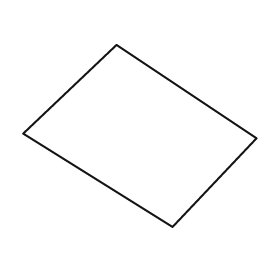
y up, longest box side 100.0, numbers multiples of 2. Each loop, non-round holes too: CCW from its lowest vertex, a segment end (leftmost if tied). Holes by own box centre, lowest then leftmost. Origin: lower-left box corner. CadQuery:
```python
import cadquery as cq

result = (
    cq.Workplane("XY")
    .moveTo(64.0, 0.0)
    .lineTo(100.0, 38.0)
    .lineTo(40.0, 78.0)
    .lineTo(0.0, 40.0)
    .close()
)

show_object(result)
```